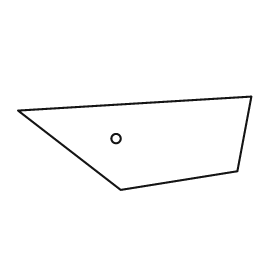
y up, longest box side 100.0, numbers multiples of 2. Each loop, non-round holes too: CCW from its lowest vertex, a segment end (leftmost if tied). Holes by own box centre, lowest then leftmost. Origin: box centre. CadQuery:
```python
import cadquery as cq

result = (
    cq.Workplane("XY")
    .moveTo(-6.0, -20.0)
    .lineTo(44.0, -12.0)
    .lineTo(50.0, 20.0)
    .lineTo(-50.0, 14.0)
    .close()
    .moveTo(-8.0, 2.0)
    .circle(2.0)
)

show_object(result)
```